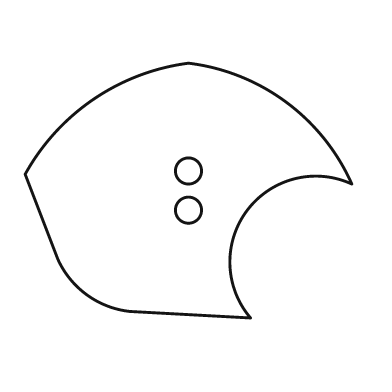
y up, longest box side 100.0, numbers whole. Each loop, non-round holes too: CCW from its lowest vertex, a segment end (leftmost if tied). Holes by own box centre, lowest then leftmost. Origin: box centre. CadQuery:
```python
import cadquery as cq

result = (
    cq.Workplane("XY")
    .moveTo(19.0, -39.0)
    .threePointArc((18.0, -6.0), (50.0, 2.0))
    .threePointArc((30.0, 27.0), (0.0, 39.0))
    .threePointArc((-29.0, 28.0), (-50.0, 5.0))
    .lineTo(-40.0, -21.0)
    .threePointArc((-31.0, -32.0), (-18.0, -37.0))
    .close()
    .moveTo(0.0, -6.0)
    .circle(4.0)
    .moveTo(0.0, 6.0)
    .circle(4.0)
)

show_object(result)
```